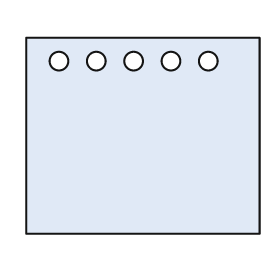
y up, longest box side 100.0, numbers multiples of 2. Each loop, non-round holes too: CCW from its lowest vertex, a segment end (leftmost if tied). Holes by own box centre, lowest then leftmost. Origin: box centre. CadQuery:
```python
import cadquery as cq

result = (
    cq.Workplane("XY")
    .moveTo(-50.0, -42.0)
    .lineTo(50.0, -42.0)
    .lineTo(50.0, 42.0)
    .lineTo(-50.0, 42.0)
    .close()
    .moveTo(-36.0, 32.0)
    .circle(4.0)
    .moveTo(-20.0, 32.0)
    .circle(4.0)
    .moveTo(-4.0, 32.0)
    .circle(4.0)
    .moveTo(12.0, 32.0)
    .circle(4.0)
    .moveTo(28.0, 32.0)
    .circle(4.0)
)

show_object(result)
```